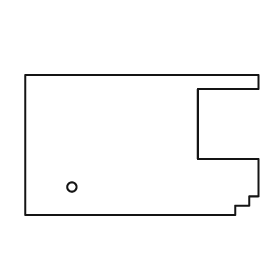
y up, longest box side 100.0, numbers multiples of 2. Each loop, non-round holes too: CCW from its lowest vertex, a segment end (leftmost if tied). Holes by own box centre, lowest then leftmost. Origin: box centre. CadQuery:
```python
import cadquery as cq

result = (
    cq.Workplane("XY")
    .moveTo(-50.0, -30.0)
    .lineTo(40.0, -30.0)
    .lineTo(40.0, -26.0)
    .lineTo(46.0, -26.0)
    .lineTo(46.0, -22.0)
    .lineTo(50.0, -22.0)
    .lineTo(50.0, -6.0)
    .lineTo(24.0, -6.0)
    .lineTo(24.0, 24.0)
    .lineTo(50.0, 24.0)
    .lineTo(50.0, 30.0)
    .lineTo(-50.0, 30.0)
    .close()
    .moveTo(-30.0, -18.0)
    .circle(2.0)
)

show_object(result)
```